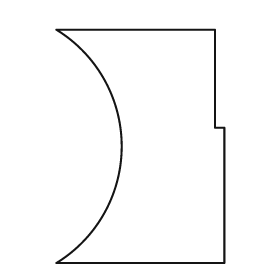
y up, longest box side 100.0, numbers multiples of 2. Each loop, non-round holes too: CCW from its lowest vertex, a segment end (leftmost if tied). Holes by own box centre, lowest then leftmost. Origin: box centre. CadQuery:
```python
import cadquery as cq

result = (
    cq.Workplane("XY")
    .moveTo(-36.0, -50.0)
    .lineTo(36.0, -50.0)
    .lineTo(36.0, 8.0)
    .lineTo(32.0, 8.0)
    .lineTo(32.0, 50.0)
    .lineTo(-36.0, 50.0)
    .threePointArc((-8.0, 0.0), (-36.0, -50.0))
    .close()
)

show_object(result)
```